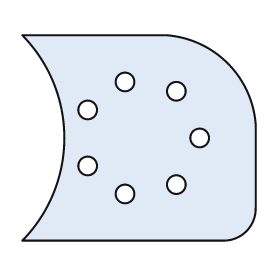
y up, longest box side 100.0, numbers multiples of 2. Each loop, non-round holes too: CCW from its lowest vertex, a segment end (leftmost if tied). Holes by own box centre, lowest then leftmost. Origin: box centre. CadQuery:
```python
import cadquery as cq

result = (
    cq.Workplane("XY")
    .moveTo(-50.0, -44.0)
    .lineTo(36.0, -44.0)
    .threePointArc((46.0, -40.0), (50.0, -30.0))
    .lineTo(50.0, 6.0)
    .threePointArc((38.0, 32.0), (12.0, 44.0))
    .lineTo(-50.0, 44.0)
    .threePointArc((-32.0, 0.0), (-50.0, -44.0))
    .close()
    .moveTo(-6.0, -24.0)
    .circle(4.0)
    .moveTo(16.0, -20.0)
    .circle(4.0)
    .moveTo(-22.0, -12.0)
    .circle(4.0)
    .moveTo(26.0, 0.0)
    .circle(4.0)
    .moveTo(-22.0, 12.0)
    .circle(4.0)
    .moveTo(16.0, 20.0)
    .circle(4.0)
    .moveTo(-6.0, 24.0)
    .circle(4.0)
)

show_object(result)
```